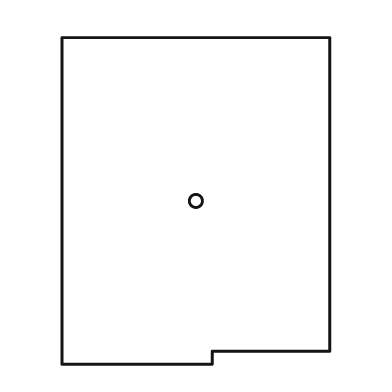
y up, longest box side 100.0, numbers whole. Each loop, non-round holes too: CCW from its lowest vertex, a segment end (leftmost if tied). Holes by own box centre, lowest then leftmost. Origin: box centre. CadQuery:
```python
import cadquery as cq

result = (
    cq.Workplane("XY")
    .moveTo(-41.0, -50.0)
    .lineTo(5.0, -50.0)
    .lineTo(5.0, -46.0)
    .lineTo(41.0, -46.0)
    .lineTo(41.0, 50.0)
    .lineTo(-41.0, 50.0)
    .close()
    .moveTo(0.0, 0.0)
    .circle(2.0)
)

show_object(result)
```